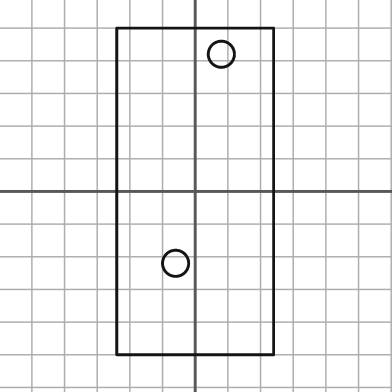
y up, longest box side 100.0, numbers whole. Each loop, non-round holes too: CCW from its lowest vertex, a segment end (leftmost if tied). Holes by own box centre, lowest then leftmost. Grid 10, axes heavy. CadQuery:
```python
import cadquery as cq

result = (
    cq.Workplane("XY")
    .moveTo(-24.0, -50.0)
    .lineTo(24.0, -50.0)
    .lineTo(24.0, 50.0)
    .lineTo(-24.0, 50.0)
    .close()
    .moveTo(-6.0, -22.0)
    .circle(4.0)
    .moveTo(8.0, 42.0)
    .circle(4.0)
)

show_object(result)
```